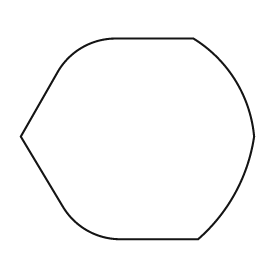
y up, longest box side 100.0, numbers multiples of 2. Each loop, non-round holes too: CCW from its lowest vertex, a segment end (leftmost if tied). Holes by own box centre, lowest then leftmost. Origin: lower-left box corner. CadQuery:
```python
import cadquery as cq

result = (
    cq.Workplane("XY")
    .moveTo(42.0, 0.0)
    .lineTo(76.0, 0.0)
    .threePointArc((92.0, 20.0), (100.0, 44.0))
    .threePointArc((92.0, 68.0), (74.0, 86.0))
    .lineTo(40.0, 86.0)
    .threePointArc((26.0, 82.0), (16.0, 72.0))
    .lineTo(0.0, 44.0)
    .lineTo(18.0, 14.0)
    .threePointArc((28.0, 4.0), (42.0, 0.0))
    .close()
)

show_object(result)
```